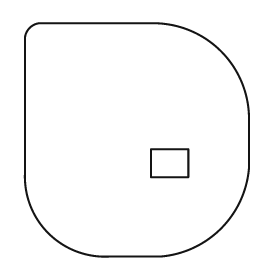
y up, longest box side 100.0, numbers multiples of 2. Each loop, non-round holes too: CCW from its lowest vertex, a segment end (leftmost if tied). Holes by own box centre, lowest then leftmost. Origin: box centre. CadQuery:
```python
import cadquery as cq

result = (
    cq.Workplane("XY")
    .moveTo(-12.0, -50.0)
    .lineTo(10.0, -50.0)
    .threePointArc((36.0, -38.0), (48.0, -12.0))
    .lineTo(48.0, 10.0)
    .threePointArc((36.0, 38.0), (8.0, 50.0))
    .lineTo(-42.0, 50.0)
    .threePointArc((-46.0, 48.0), (-48.0, 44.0))
    .lineTo(-48.0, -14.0)
    .threePointArc((-38.0, -40.0), (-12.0, -50.0))
    .close()
    .moveTo(6.0, -16.0)
    .lineTo(22.0, -16.0)
    .lineTo(22.0, -4.0)
    .lineTo(6.0, -4.0)
    .close()
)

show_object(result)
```